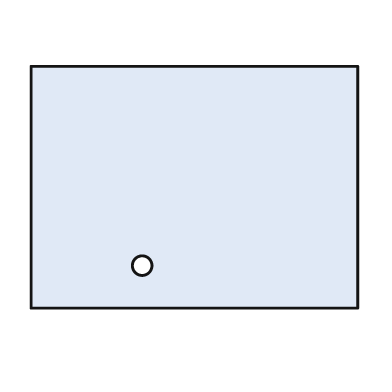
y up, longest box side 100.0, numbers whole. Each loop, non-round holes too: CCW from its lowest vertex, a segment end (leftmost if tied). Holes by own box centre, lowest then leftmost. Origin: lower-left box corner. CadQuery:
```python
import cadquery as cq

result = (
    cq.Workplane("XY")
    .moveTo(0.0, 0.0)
    .lineTo(100.0, 0.0)
    .lineTo(100.0, 74.0)
    .lineTo(0.0, 74.0)
    .close()
    .moveTo(34.0, 13.0)
    .circle(3.0)
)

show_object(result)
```